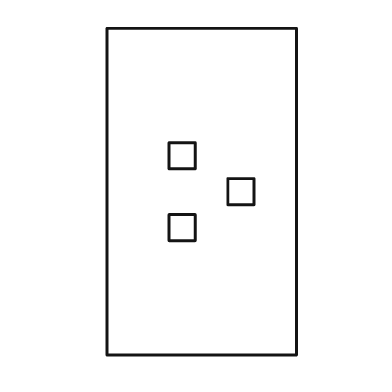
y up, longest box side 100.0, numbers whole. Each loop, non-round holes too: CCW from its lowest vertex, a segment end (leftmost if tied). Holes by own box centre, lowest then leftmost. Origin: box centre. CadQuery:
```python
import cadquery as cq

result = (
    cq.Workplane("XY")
    .moveTo(-29.0, -50.0)
    .lineTo(29.0, -50.0)
    .lineTo(29.0, 50.0)
    .lineTo(-29.0, 50.0)
    .close()
    .moveTo(-10.0, -15.0)
    .lineTo(-2.0, -15.0)
    .lineTo(-2.0, -7.0)
    .lineTo(-10.0, -7.0)
    .close()
    .moveTo(8.0, -4.0)
    .lineTo(16.0, -4.0)
    .lineTo(16.0, 4.0)
    .lineTo(8.0, 4.0)
    .close()
    .moveTo(-10.0, 7.0)
    .lineTo(-2.0, 7.0)
    .lineTo(-2.0, 15.0)
    .lineTo(-10.0, 15.0)
    .close()
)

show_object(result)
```